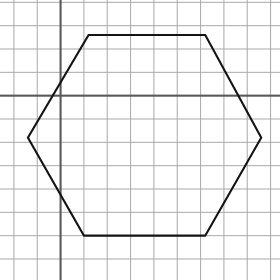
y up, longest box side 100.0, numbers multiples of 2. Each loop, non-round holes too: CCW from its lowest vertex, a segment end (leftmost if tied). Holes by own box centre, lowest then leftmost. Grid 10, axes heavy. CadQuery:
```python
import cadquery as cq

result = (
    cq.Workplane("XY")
    .moveTo(10.0, -60.0)
    .lineTo(62.0, -60.0)
    .lineTo(86.0, -18.0)
    .lineTo(62.0, 26.0)
    .lineTo(12.0, 26.0)
    .lineTo(-14.0, -18.0)
    .close()
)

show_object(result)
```